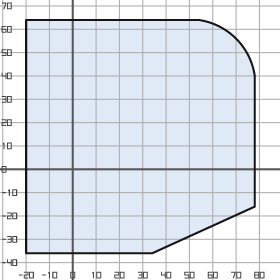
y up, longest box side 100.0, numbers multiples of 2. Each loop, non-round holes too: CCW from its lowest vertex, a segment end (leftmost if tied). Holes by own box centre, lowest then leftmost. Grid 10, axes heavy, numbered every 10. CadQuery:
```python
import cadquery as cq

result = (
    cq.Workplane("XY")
    .moveTo(-20.0, -36.0)
    .lineTo(34.0, -36.0)
    .lineTo(78.0, -16.0)
    .lineTo(78.0, 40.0)
    .threePointArc((70.0, 56.0), (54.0, 64.0))
    .lineTo(-20.0, 64.0)
    .close()
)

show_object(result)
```